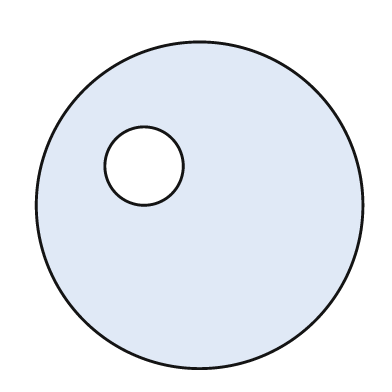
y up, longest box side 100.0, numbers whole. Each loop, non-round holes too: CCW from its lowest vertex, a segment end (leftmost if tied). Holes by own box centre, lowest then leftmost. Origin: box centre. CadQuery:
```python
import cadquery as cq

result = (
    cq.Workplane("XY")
    .moveTo(0.0, 0.0)
    .circle(50.0)
    .moveTo(-17.0, 12.0)
    .circle(12.0)
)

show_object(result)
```